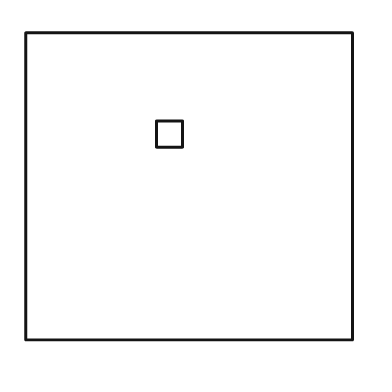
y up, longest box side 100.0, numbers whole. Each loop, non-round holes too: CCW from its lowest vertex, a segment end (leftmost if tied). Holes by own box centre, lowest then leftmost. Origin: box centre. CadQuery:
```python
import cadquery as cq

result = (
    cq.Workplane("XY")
    .moveTo(-50.0, -47.0)
    .lineTo(50.0, -47.0)
    .lineTo(50.0, 47.0)
    .lineTo(-50.0, 47.0)
    .close()
    .moveTo(-10.0, 12.0)
    .lineTo(-2.0, 12.0)
    .lineTo(-2.0, 20.0)
    .lineTo(-10.0, 20.0)
    .close()
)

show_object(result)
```